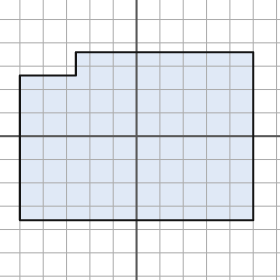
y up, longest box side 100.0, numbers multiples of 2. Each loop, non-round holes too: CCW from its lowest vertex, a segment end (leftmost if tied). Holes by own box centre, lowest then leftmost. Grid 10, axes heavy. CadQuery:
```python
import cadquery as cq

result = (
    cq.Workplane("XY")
    .moveTo(-50.0, -36.0)
    .lineTo(50.0, -36.0)
    .lineTo(50.0, 36.0)
    .lineTo(-26.0, 36.0)
    .lineTo(-26.0, 26.0)
    .lineTo(-50.0, 26.0)
    .close()
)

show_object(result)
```